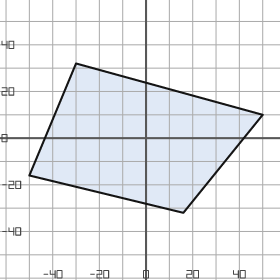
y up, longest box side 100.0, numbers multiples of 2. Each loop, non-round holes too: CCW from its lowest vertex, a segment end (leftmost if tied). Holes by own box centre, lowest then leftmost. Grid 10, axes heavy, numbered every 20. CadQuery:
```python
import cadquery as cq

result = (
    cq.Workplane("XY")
    .moveTo(16.0, -32.0)
    .lineTo(50.0, 10.0)
    .lineTo(-30.0, 32.0)
    .lineTo(-50.0, -16.0)
    .close()
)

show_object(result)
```